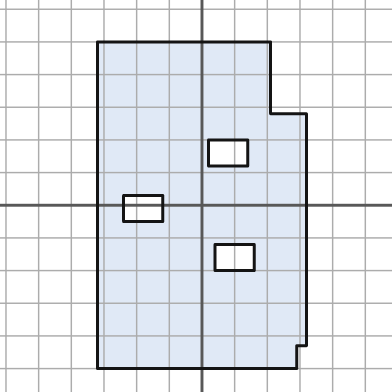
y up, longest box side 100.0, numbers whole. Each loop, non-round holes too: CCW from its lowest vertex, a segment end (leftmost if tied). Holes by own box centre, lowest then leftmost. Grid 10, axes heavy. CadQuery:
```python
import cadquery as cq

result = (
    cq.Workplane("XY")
    .moveTo(-32.0, -50.0)
    .lineTo(29.0, -50.0)
    .lineTo(29.0, -43.0)
    .lineTo(32.0, -43.0)
    .lineTo(32.0, 28.0)
    .lineTo(21.0, 28.0)
    .lineTo(21.0, 50.0)
    .lineTo(-32.0, 50.0)
    .close()
    .moveTo(4.0, -20.0)
    .lineTo(16.0, -20.0)
    .lineTo(16.0, -12.0)
    .lineTo(4.0, -12.0)
    .close()
    .moveTo(-24.0, -5.0)
    .lineTo(-12.0, -5.0)
    .lineTo(-12.0, 3.0)
    .lineTo(-24.0, 3.0)
    .close()
    .moveTo(2.0, 12.0)
    .lineTo(14.0, 12.0)
    .lineTo(14.0, 20.0)
    .lineTo(2.0, 20.0)
    .close()
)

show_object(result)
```